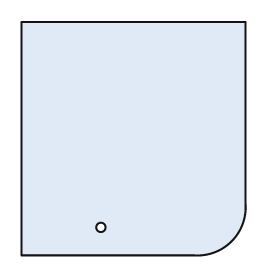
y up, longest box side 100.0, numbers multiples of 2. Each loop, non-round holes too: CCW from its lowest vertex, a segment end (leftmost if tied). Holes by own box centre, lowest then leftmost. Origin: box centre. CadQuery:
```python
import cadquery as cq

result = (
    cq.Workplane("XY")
    .moveTo(-48.0, -50.0)
    .lineTo(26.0, -50.0)
    .threePointArc((42.0, -44.0), (48.0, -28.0))
    .lineTo(48.0, 50.0)
    .lineTo(-48.0, 50.0)
    .close()
    .moveTo(-14.0, -38.0)
    .circle(2.0)
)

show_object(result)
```